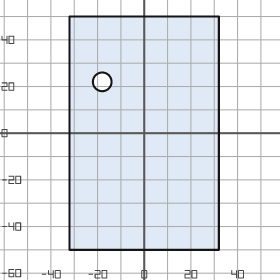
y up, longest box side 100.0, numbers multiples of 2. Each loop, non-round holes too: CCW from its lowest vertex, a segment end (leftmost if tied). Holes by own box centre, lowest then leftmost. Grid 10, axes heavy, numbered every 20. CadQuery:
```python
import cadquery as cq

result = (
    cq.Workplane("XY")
    .moveTo(-32.0, -50.0)
    .lineTo(32.0, -50.0)
    .lineTo(32.0, 50.0)
    .lineTo(-32.0, 50.0)
    .close()
    .moveTo(-18.0, 22.0)
    .circle(4.0)
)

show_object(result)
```